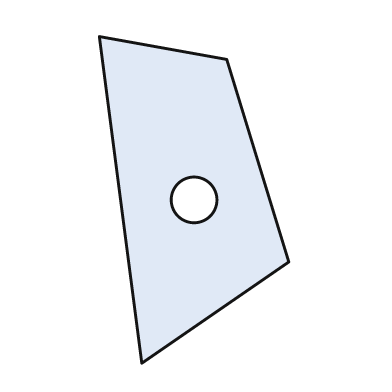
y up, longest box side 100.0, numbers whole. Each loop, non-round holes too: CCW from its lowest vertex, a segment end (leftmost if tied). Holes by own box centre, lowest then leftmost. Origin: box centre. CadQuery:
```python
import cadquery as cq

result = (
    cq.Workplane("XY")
    .moveTo(-16.0, -50.0)
    .lineTo(29.0, -19.0)
    .lineTo(10.0, 43.0)
    .lineTo(-29.0, 50.0)
    .close()
    .moveTo(0.0, 0.0)
    .circle(7.0)
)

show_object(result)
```